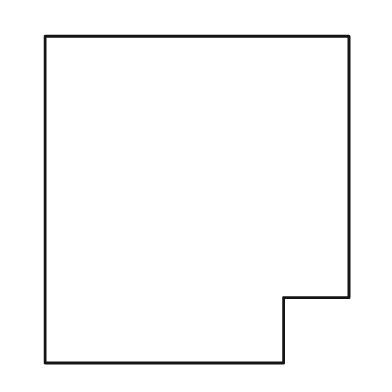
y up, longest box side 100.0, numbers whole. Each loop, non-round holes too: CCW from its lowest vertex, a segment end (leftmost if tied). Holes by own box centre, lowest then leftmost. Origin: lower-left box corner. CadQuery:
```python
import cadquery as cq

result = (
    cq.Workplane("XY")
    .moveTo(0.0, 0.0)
    .lineTo(73.0, 0.0)
    .lineTo(73.0, 20.0)
    .lineTo(93.0, 20.0)
    .lineTo(93.0, 100.0)
    .lineTo(0.0, 100.0)
    .close()
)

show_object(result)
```